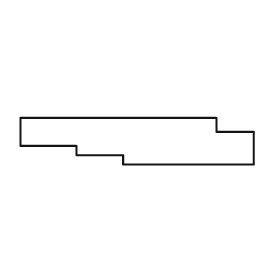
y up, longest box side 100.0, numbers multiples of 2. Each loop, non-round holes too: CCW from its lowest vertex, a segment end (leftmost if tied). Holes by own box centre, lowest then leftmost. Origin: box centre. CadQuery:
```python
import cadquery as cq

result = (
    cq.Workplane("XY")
    .moveTo(-6.0, -10.0)
    .lineTo(50.0, -10.0)
    .lineTo(50.0, 4.0)
    .lineTo(34.0, 4.0)
    .lineTo(34.0, 10.0)
    .lineTo(-50.0, 10.0)
    .lineTo(-50.0, -2.0)
    .lineTo(-26.0, -2.0)
    .lineTo(-26.0, -6.0)
    .lineTo(-6.0, -6.0)
    .close()
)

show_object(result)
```